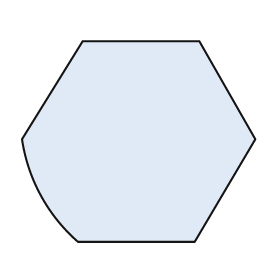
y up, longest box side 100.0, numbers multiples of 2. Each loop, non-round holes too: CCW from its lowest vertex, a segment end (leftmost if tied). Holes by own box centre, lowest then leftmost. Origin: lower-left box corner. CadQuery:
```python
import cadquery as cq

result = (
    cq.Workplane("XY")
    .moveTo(24.0, 0.0)
    .lineTo(74.0, 0.0)
    .lineTo(100.0, 44.0)
    .lineTo(76.0, 86.0)
    .lineTo(26.0, 86.0)
    .lineTo(0.0, 44.0)
    .threePointArc((8.0, 20.0), (24.0, 0.0))
    .close()
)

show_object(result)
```